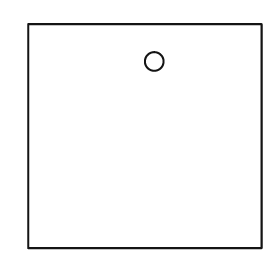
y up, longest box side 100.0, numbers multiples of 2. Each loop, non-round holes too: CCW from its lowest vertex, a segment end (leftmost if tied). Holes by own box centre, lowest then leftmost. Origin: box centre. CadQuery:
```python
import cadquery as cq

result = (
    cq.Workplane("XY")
    .moveTo(-50.0, -48.0)
    .lineTo(50.0, -48.0)
    .lineTo(50.0, 48.0)
    .lineTo(-50.0, 48.0)
    .close()
    .moveTo(4.0, 32.0)
    .circle(4.0)
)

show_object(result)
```